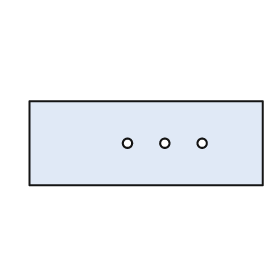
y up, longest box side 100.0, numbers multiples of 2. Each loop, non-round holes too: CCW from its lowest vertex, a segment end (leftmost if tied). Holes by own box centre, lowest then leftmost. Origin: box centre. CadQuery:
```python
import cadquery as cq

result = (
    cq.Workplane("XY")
    .moveTo(-50.0, -18.0)
    .lineTo(50.0, -18.0)
    .lineTo(50.0, 18.0)
    .lineTo(-50.0, 18.0)
    .close()
    .moveTo(-8.0, 0.0)
    .circle(2.0)
    .moveTo(8.0, 0.0)
    .circle(2.0)
    .moveTo(24.0, 0.0)
    .circle(2.0)
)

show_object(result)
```